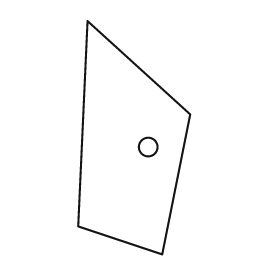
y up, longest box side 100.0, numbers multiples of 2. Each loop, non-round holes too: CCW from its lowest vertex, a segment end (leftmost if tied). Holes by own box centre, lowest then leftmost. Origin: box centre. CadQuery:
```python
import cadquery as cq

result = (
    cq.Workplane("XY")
    .moveTo(12.0, -50.0)
    .lineTo(24.0, 10.0)
    .lineTo(-20.0, 50.0)
    .lineTo(-24.0, -38.0)
    .close()
    .moveTo(6.0, -4.0)
    .circle(4.0)
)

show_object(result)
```